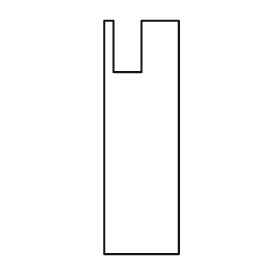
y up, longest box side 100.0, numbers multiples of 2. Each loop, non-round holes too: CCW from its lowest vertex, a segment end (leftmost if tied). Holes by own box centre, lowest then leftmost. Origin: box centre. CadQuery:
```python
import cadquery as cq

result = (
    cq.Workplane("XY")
    .moveTo(-16.0, -50.0)
    .lineTo(16.0, -50.0)
    .lineTo(16.0, 50.0)
    .lineTo(0.0, 50.0)
    .lineTo(0.0, 28.0)
    .lineTo(-12.0, 28.0)
    .lineTo(-12.0, 50.0)
    .lineTo(-16.0, 50.0)
    .close()
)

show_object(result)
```